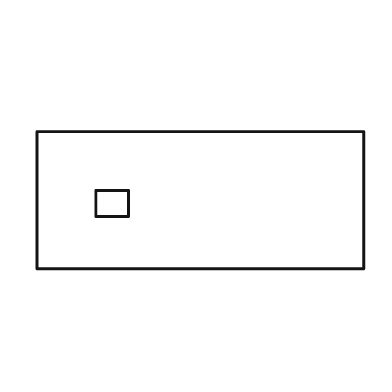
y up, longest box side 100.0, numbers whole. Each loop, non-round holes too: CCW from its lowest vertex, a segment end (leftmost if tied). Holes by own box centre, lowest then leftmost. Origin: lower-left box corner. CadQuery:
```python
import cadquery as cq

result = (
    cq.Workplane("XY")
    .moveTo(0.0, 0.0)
    .lineTo(100.0, 0.0)
    .lineTo(100.0, 42.0)
    .lineTo(0.0, 42.0)
    .close()
    .moveTo(18.0, 16.0)
    .lineTo(28.0, 16.0)
    .lineTo(28.0, 24.0)
    .lineTo(18.0, 24.0)
    .close()
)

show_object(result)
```